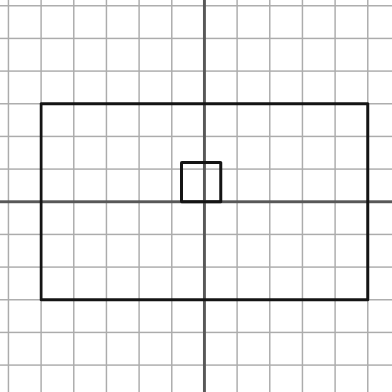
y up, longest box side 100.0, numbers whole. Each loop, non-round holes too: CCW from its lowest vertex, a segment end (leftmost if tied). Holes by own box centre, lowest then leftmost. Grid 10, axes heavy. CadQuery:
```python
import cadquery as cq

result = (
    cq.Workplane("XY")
    .moveTo(-50.0, -30.0)
    .lineTo(50.0, -30.0)
    .lineTo(50.0, 30.0)
    .lineTo(-50.0, 30.0)
    .close()
    .moveTo(-7.0, 0.0)
    .lineTo(5.0, 0.0)
    .lineTo(5.0, 12.0)
    .lineTo(-7.0, 12.0)
    .close()
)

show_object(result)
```